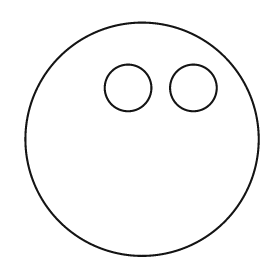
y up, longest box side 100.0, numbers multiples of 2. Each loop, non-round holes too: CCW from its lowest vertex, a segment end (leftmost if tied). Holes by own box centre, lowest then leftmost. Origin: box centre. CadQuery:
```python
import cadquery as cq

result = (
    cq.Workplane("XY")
    .moveTo(0.0, 0.0)
    .circle(50.0)
    .moveTo(-6.0, 22.0)
    .circle(10.0)
    .moveTo(22.0, 22.0)
    .circle(10.0)
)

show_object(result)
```